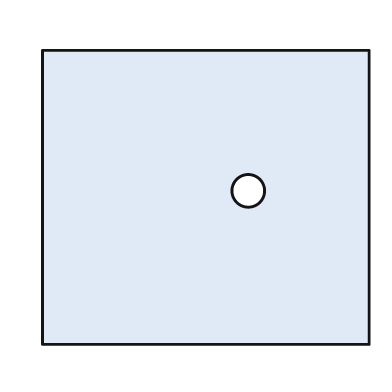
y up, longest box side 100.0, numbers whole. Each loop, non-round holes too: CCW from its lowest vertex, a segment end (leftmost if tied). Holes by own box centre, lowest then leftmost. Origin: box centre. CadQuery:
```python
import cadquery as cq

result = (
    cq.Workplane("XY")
    .moveTo(-50.0, -45.0)
    .lineTo(50.0, -45.0)
    .lineTo(50.0, 45.0)
    .lineTo(-50.0, 45.0)
    .close()
    .moveTo(13.0, 2.0)
    .circle(5.0)
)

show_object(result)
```